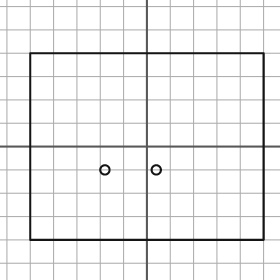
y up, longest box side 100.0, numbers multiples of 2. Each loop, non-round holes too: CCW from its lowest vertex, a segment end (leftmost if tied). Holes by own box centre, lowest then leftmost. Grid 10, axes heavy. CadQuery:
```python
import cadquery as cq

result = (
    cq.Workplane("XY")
    .moveTo(-50.0, -40.0)
    .lineTo(50.0, -40.0)
    .lineTo(50.0, 40.0)
    .lineTo(-50.0, 40.0)
    .close()
    .moveTo(-18.0, -10.0)
    .circle(2.0)
    .moveTo(4.0, -10.0)
    .circle(2.0)
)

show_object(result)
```